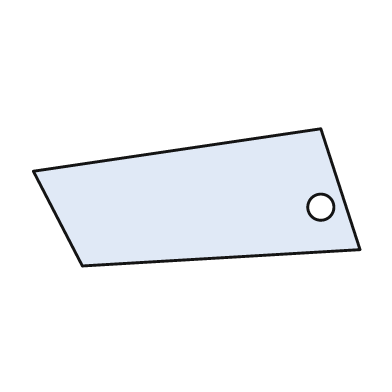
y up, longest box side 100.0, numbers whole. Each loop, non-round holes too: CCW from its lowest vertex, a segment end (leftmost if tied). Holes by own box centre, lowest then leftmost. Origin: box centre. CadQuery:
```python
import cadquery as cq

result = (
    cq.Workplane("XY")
    .moveTo(-35.0, -21.0)
    .lineTo(50.0, -16.0)
    .lineTo(38.0, 21.0)
    .lineTo(-50.0, 8.0)
    .close()
    .moveTo(38.0, -3.0)
    .circle(4.0)
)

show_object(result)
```